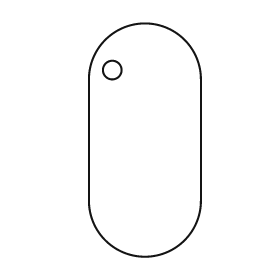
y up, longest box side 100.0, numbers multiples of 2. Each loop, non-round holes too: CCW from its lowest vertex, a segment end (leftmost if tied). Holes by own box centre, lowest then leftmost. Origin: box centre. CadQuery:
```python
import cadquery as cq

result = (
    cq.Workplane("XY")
    .moveTo(-24.0, -26.0)
    .threePointArc((0.0, -50.0), (24.0, -26.0))
    .lineTo(24.0, 26.0)
    .threePointArc((0.0, 50.0), (-24.0, 26.0))
    .close()
    .moveTo(-14.0, 30.0)
    .circle(4.0)
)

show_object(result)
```